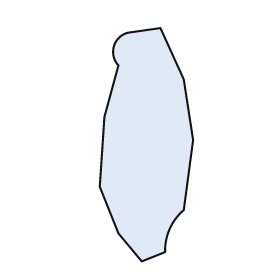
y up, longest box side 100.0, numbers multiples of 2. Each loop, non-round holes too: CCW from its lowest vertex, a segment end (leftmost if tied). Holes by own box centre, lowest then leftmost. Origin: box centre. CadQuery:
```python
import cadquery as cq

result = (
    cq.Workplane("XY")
    .moveTo(-2.0, -50.0)
    .lineTo(8.0, -46.0)
    .threePointArc((10.0, -36.0), (16.0, -28.0))
    .lineTo(20.0, 2.0)
    .lineTo(16.0, 28.0)
    .lineTo(6.0, 50.0)
    .lineTo(-8.0, 48.0)
    .threePointArc((-14.0, 42.0), (-12.0, 34.0))
    .lineTo(-18.0, 12.0)
    .lineTo(-20.0, -18.0)
    .lineTo(-12.0, -38.0)
    .close()
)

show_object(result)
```